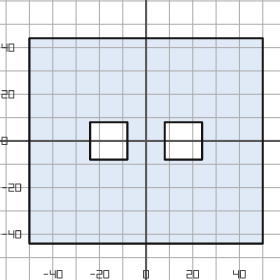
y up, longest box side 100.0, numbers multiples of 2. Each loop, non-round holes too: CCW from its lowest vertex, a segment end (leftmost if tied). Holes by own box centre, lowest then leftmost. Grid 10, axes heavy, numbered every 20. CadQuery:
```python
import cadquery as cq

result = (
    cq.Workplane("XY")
    .moveTo(-50.0, -44.0)
    .lineTo(50.0, -44.0)
    .lineTo(50.0, 44.0)
    .lineTo(-50.0, 44.0)
    .close()
    .moveTo(-24.0, -8.0)
    .lineTo(-8.0, -8.0)
    .lineTo(-8.0, 8.0)
    .lineTo(-24.0, 8.0)
    .close()
    .moveTo(8.0, -8.0)
    .lineTo(24.0, -8.0)
    .lineTo(24.0, 8.0)
    .lineTo(8.0, 8.0)
    .close()
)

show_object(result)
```